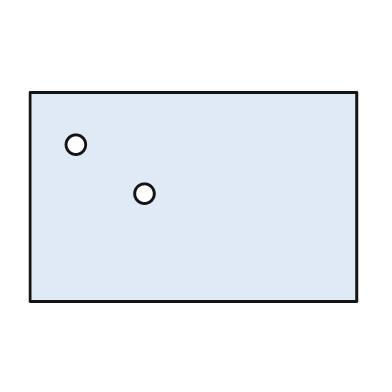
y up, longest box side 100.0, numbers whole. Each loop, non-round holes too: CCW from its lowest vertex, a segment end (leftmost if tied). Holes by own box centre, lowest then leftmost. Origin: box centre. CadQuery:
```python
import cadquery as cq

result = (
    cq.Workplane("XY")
    .moveTo(-50.0, -32.0)
    .lineTo(50.0, -32.0)
    .lineTo(50.0, 32.0)
    .lineTo(-50.0, 32.0)
    .close()
    .moveTo(-15.0, 1.0)
    .circle(3.0)
    .moveTo(-36.0, 16.0)
    .circle(3.0)
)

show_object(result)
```